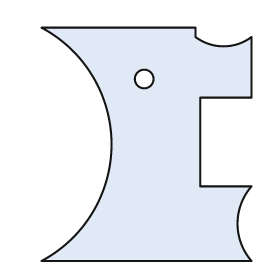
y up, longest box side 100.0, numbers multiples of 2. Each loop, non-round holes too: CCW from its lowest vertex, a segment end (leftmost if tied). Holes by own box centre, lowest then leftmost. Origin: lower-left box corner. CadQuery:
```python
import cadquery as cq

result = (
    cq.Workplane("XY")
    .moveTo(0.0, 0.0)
    .lineTo(90.0, 0.0)
    .threePointArc((84.0, 16.0), (90.0, 32.0))
    .lineTo(68.0, 32.0)
    .lineTo(68.0, 70.0)
    .lineTo(90.0, 70.0)
    .lineTo(90.0, 96.0)
    .threePointArc((78.0, 92.0), (66.0, 96.0))
    .lineTo(66.0, 100.0)
    .lineTo(0.0, 100.0)
    .threePointArc((30.0, 50.0), (0.0, 0.0))
    .close()
    .moveTo(44.0, 78.0)
    .circle(4.0)
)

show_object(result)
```